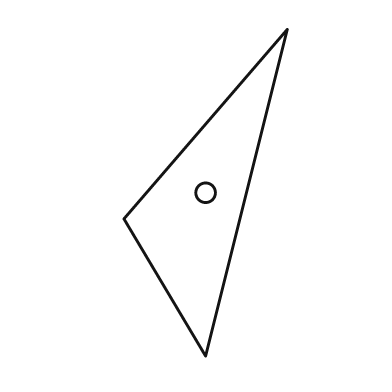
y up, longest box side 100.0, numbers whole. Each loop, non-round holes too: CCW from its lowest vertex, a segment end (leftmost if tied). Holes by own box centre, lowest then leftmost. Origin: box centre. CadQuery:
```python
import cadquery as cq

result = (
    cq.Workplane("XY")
    .moveTo(0.0, -50.0)
    .lineTo(25.0, 50.0)
    .lineTo(-25.0, -8.0)
    .close()
    .moveTo(0.0, 0.0)
    .circle(3.0)
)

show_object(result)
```